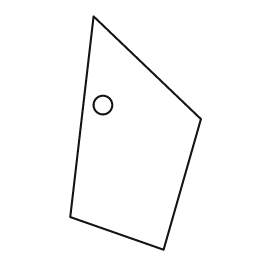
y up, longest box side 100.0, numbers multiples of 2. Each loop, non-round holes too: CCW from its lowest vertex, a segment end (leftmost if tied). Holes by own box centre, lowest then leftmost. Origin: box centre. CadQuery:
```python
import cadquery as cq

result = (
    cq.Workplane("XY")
    .moveTo(12.0, -50.0)
    .lineTo(28.0, 6.0)
    .lineTo(-18.0, 50.0)
    .lineTo(-28.0, -36.0)
    .close()
    .moveTo(-14.0, 12.0)
    .circle(4.0)
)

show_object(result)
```